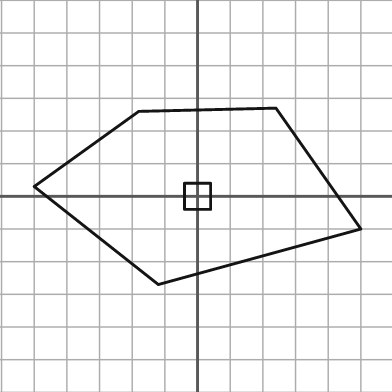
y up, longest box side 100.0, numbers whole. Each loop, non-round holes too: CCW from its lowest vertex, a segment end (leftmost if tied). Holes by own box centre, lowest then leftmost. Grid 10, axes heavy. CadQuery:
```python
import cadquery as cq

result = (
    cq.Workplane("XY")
    .moveTo(-12.0, -27.0)
    .lineTo(50.0, -10.0)
    .lineTo(24.0, 27.0)
    .lineTo(-18.0, 26.0)
    .lineTo(-50.0, 3.0)
    .close()
    .moveTo(-4.0, -4.0)
    .lineTo(4.0, -4.0)
    .lineTo(4.0, 4.0)
    .lineTo(-4.0, 4.0)
    .close()
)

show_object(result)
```